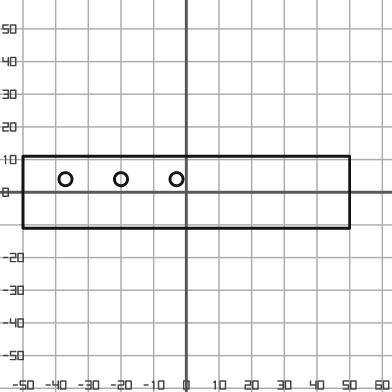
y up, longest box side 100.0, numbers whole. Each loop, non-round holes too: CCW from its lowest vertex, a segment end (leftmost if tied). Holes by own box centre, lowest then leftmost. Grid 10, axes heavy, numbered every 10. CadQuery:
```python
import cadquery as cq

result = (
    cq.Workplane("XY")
    .moveTo(-50.0, -11.0)
    .lineTo(50.0, -11.0)
    .lineTo(50.0, 11.0)
    .lineTo(-50.0, 11.0)
    .close()
    .moveTo(-37.0, 4.0)
    .circle(2.0)
    .moveTo(-20.0, 4.0)
    .circle(2.0)
    .moveTo(-3.0, 4.0)
    .circle(2.0)
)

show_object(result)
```